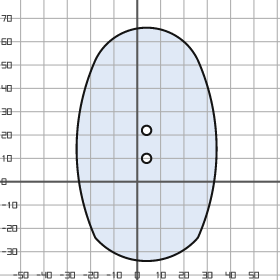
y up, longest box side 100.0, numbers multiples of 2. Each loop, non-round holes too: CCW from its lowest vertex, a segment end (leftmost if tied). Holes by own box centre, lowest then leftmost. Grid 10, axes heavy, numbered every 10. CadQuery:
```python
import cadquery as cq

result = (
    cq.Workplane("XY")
    .moveTo(-18.0, -24.0)
    .threePointArc((4.0, -34.0), (26.0, -24.0))
    .threePointArc((34.0, 14.0), (26.0, 52.0))
    .threePointArc((4.0, 66.0), (-18.0, 52.0))
    .threePointArc((-26.0, 14.0), (-18.0, -24.0))
    .close()
    .moveTo(4.0, 10.0)
    .circle(2.0)
    .moveTo(4.0, 22.0)
    .circle(2.0)
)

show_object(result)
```